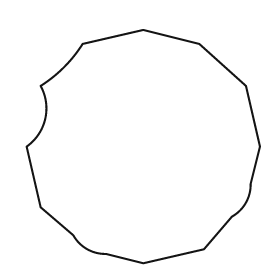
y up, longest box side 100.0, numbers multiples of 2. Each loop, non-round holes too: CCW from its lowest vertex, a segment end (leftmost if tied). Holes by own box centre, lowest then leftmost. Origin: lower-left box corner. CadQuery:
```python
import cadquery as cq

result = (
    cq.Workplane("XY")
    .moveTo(50.0, 0.0)
    .lineTo(76.0, 6.0)
    .lineTo(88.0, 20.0)
    .threePointArc((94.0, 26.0), (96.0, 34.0))
    .lineTo(100.0, 50.0)
    .lineTo(94.0, 76.0)
    .lineTo(74.0, 94.0)
    .lineTo(50.0, 100.0)
    .lineTo(24.0, 94.0)
    .threePointArc((16.0, 84.0), (6.0, 76.0))
    .threePointArc((8.0, 62.0), (0.0, 50.0))
    .lineTo(6.0, 24.0)
    .lineTo(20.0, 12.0)
    .threePointArc((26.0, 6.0), (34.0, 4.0))
    .close()
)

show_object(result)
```